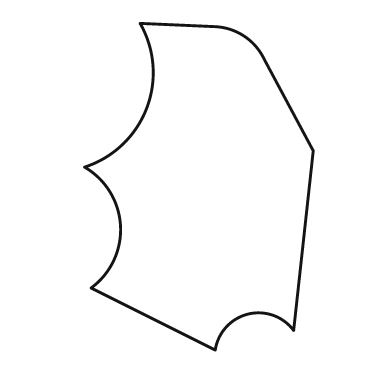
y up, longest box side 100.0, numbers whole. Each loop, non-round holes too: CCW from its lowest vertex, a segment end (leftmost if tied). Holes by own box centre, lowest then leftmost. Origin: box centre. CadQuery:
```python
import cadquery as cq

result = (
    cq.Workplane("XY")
    .moveTo(5.0, -50.0)
    .threePointArc((15.0, -39.0), (29.0, -44.0))
    .lineTo(35.0, 11.0)
    .lineTo(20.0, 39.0)
    .threePointArc((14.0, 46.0), (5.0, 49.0))
    .lineTo(-18.0, 50.0)
    .threePointArc((-16.0, 24.0), (-35.0, 6.0))
    .threePointArc((-24.0, -12.0), (-33.0, -31.0))
    .close()
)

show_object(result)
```